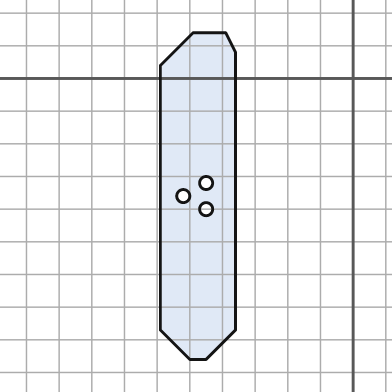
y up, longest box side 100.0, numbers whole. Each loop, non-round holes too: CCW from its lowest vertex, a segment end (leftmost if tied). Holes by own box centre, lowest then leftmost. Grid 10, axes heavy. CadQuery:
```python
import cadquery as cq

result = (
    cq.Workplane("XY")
    .moveTo(-50.0, -86.0)
    .lineTo(-45.0, -86.0)
    .lineTo(-36.0, -77.0)
    .lineTo(-36.0, 8.0)
    .lineTo(-39.0, 14.0)
    .lineTo(-49.0, 14.0)
    .lineTo(-59.0, 4.0)
    .lineTo(-59.0, -77.0)
    .close()
    .moveTo(-45.0, -40.0)
    .circle(2.0)
    .moveTo(-52.0, -36.0)
    .circle(2.0)
    .moveTo(-45.0, -32.0)
    .circle(2.0)
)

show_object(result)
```